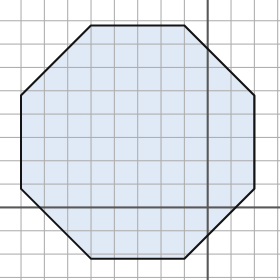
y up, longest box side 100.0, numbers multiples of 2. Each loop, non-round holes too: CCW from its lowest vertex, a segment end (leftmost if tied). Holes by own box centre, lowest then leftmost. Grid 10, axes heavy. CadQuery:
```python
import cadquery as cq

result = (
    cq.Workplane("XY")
    .moveTo(-50.0, -22.0)
    .lineTo(-10.0, -22.0)
    .lineTo(20.0, 8.0)
    .lineTo(20.0, 48.0)
    .lineTo(-10.0, 78.0)
    .lineTo(-50.0, 78.0)
    .lineTo(-80.0, 48.0)
    .lineTo(-80.0, 8.0)
    .close()
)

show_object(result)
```